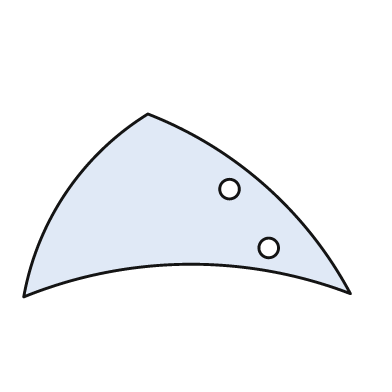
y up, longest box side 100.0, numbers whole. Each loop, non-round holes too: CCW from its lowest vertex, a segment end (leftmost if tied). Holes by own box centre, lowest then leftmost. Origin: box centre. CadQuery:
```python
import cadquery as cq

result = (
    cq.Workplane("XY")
    .moveTo(-50.0, -28.0)
    .threePointArc((0.0, -18.0), (50.0, -27.0))
    .threePointArc((24.0, 6.0), (-12.0, 28.0))
    .threePointArc((-37.0, 4.0), (-50.0, -28.0))
    .close()
    .moveTo(25.0, -13.0)
    .circle(3.0)
    .moveTo(13.0, 5.0)
    .circle(3.0)
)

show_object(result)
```